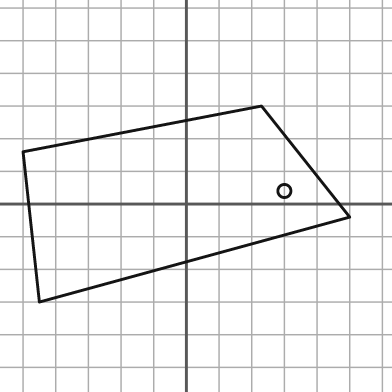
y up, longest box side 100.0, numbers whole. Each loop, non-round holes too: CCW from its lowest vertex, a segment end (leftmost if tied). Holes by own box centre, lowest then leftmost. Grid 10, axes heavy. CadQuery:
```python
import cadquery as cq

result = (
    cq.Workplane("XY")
    .moveTo(-45.0, -30.0)
    .lineTo(50.0, -4.0)
    .lineTo(23.0, 30.0)
    .lineTo(-50.0, 16.0)
    .close()
    .moveTo(30.0, 4.0)
    .circle(2.0)
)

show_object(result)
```